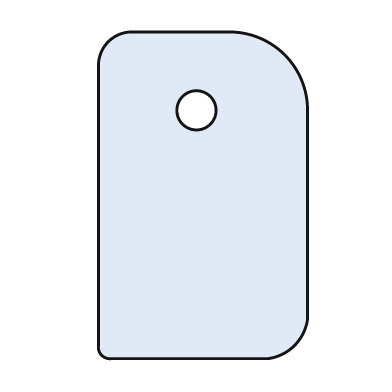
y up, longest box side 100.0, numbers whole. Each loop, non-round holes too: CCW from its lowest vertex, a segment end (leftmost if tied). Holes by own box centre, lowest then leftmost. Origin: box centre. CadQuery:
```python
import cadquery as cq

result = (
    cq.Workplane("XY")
    .moveTo(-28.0, -50.0)
    .lineTo(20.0, -50.0)
    .threePointArc((28.0, -46.0), (32.0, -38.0))
    .lineTo(32.0, 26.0)
    .threePointArc((25.0, 43.0), (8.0, 50.0))
    .lineTo(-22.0, 50.0)
    .threePointArc((-29.0, 47.0), (-32.0, 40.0))
    .lineTo(-32.0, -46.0)
    .threePointArc((-31.0, -49.0), (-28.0, -50.0))
    .close()
    .moveTo(-2.0, 26.0)
    .circle(6.0)
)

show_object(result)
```